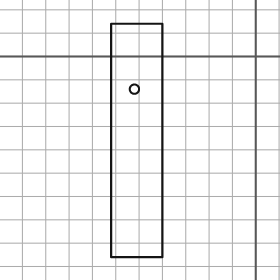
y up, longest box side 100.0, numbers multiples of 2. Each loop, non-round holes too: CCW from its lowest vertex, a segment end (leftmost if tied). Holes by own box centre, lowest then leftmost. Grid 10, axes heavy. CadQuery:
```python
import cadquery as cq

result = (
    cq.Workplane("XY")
    .moveTo(-62.0, -86.0)
    .lineTo(-40.0, -86.0)
    .lineTo(-40.0, 14.0)
    .lineTo(-62.0, 14.0)
    .close()
    .moveTo(-52.0, -14.0)
    .circle(2.0)
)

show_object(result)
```